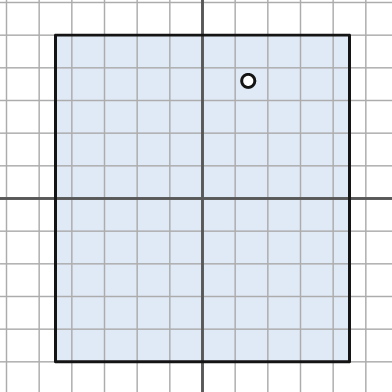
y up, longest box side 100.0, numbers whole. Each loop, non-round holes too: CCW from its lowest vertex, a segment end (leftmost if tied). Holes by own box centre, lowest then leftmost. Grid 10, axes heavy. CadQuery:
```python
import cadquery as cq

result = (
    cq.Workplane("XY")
    .moveTo(-45.0, -50.0)
    .lineTo(45.0, -50.0)
    .lineTo(45.0, 50.0)
    .lineTo(-45.0, 50.0)
    .close()
    .moveTo(14.0, 36.0)
    .circle(2.0)
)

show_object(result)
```